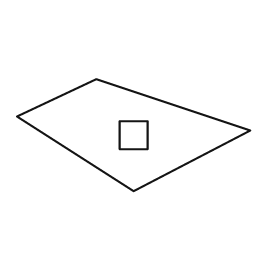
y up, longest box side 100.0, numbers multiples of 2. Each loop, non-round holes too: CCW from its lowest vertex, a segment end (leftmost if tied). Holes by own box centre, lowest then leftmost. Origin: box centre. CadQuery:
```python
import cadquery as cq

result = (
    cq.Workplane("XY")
    .moveTo(0.0, -24.0)
    .lineTo(50.0, 2.0)
    .lineTo(-16.0, 24.0)
    .lineTo(-50.0, 8.0)
    .close()
    .moveTo(-6.0, -6.0)
    .lineTo(6.0, -6.0)
    .lineTo(6.0, 6.0)
    .lineTo(-6.0, 6.0)
    .close()
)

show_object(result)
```